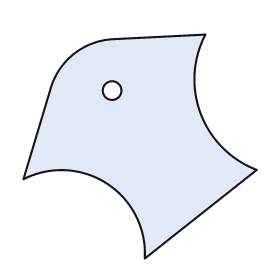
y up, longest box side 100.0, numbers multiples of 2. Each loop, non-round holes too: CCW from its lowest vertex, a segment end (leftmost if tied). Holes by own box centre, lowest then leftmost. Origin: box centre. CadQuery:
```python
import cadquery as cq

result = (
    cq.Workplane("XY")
    .moveTo(2.0, -48.0)
    .lineTo(50.0, -10.0)
    .threePointArc((26.0, 14.0), (28.0, 48.0))
    .lineTo(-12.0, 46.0)
    .threePointArc((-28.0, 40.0), (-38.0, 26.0))
    .lineTo(-50.0, -14.0)
    .threePointArc((-14.0, -16.0), (2.0, -48.0))
    .close()
    .moveTo(-12.0, 24.0)
    .circle(4.0)
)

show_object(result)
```